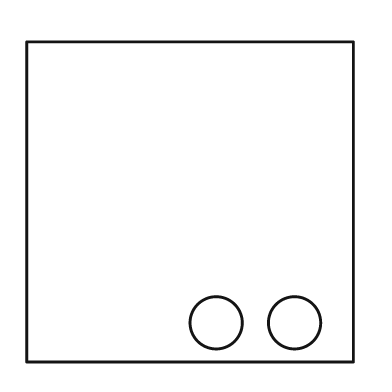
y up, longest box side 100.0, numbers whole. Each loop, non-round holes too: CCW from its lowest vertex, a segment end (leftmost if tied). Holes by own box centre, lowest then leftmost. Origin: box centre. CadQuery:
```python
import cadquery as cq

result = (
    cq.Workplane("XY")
    .moveTo(-50.0, -49.0)
    .lineTo(50.0, -49.0)
    .lineTo(50.0, 49.0)
    .lineTo(-50.0, 49.0)
    .close()
    .moveTo(8.0, -37.0)
    .circle(8.0)
    .moveTo(32.0, -37.0)
    .circle(8.0)
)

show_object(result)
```